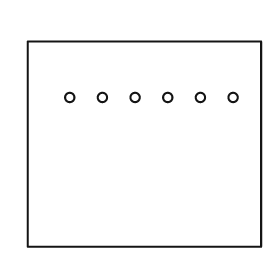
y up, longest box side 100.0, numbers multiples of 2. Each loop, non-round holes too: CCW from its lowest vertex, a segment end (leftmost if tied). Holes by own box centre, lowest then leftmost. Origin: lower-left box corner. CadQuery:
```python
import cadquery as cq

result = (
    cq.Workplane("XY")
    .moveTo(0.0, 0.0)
    .lineTo(100.0, 0.0)
    .lineTo(100.0, 88.0)
    .lineTo(0.0, 88.0)
    .close()
    .moveTo(18.0, 64.0)
    .circle(2.0)
    .moveTo(32.0, 64.0)
    .circle(2.0)
    .moveTo(46.0, 64.0)
    .circle(2.0)
    .moveTo(60.0, 64.0)
    .circle(2.0)
    .moveTo(74.0, 64.0)
    .circle(2.0)
    .moveTo(88.0, 64.0)
    .circle(2.0)
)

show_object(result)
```